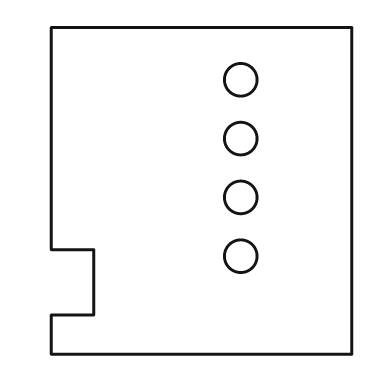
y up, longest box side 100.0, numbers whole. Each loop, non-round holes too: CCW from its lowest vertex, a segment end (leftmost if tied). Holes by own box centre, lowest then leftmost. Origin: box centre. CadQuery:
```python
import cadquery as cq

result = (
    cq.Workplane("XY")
    .moveTo(-46.0, -50.0)
    .lineTo(46.0, -50.0)
    .lineTo(46.0, 50.0)
    .lineTo(-46.0, 50.0)
    .lineTo(-46.0, -18.0)
    .lineTo(-33.0, -18.0)
    .lineTo(-33.0, -38.0)
    .lineTo(-46.0, -38.0)
    .close()
    .moveTo(12.0, -20.0)
    .circle(5.0)
    .moveTo(12.0, -2.0)
    .circle(5.0)
    .moveTo(12.0, 16.0)
    .circle(5.0)
    .moveTo(12.0, 34.0)
    .circle(5.0)
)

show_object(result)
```